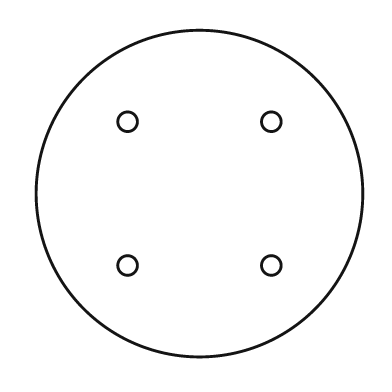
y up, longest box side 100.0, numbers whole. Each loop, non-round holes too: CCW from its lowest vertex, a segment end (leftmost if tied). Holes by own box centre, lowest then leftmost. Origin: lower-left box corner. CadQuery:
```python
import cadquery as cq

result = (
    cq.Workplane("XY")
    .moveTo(50.0, 50.0)
    .circle(50.0)
    .moveTo(28.0, 28.0)
    .circle(3.0)
    .moveTo(72.0, 28.0)
    .circle(3.0)
    .moveTo(28.0, 72.0)
    .circle(3.0)
    .moveTo(72.0, 72.0)
    .circle(3.0)
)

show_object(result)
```